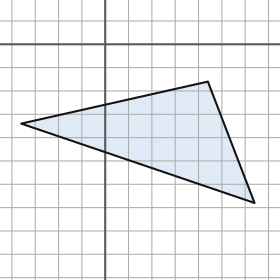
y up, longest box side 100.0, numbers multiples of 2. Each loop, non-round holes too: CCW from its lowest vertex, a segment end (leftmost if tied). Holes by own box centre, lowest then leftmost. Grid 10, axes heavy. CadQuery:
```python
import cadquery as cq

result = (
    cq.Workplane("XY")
    .moveTo(64.0, -68.0)
    .lineTo(44.0, -16.0)
    .lineTo(-36.0, -34.0)
    .close()
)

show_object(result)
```